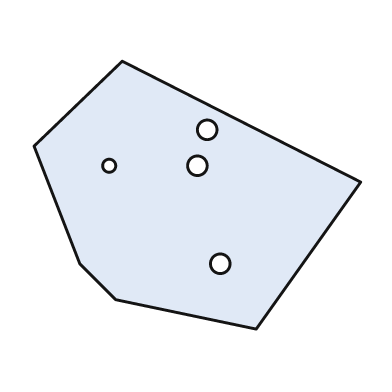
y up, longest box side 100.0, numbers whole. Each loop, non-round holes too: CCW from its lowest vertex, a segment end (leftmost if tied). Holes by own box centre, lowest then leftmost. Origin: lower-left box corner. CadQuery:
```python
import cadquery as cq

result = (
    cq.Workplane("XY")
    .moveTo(68.0, 0.0)
    .lineTo(100.0, 45.0)
    .lineTo(27.0, 82.0)
    .lineTo(0.0, 56.0)
    .lineTo(14.0, 20.0)
    .lineTo(25.0, 9.0)
    .close()
    .moveTo(57.0, 20.0)
    .circle(3.0)
    .moveTo(23.0, 50.0)
    .circle(2.0)
    .moveTo(50.0, 50.0)
    .circle(3.0)
    .moveTo(53.0, 61.0)
    .circle(3.0)
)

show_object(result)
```